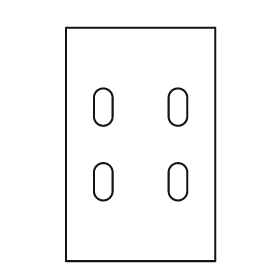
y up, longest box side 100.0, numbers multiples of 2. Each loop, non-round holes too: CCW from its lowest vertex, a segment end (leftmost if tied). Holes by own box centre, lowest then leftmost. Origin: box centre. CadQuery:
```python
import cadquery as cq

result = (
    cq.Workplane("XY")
    .moveTo(-32.0, -50.0)
    .lineTo(32.0, -50.0)
    .lineTo(32.0, 50.0)
    .lineTo(-32.0, 50.0)
    .close()
    .moveTo(-20.0, -20.0)
    .threePointArc((-16.0, -24.0), (-12.0, -20.0))
    .lineTo(-12.0, -12.0)
    .threePointArc((-16.0, -8.0), (-20.0, -12.0))
    .close()
    .moveTo(12.0, -20.0)
    .threePointArc((16.0, -24.0), (20.0, -20.0))
    .lineTo(20.0, -12.0)
    .threePointArc((16.0, -8.0), (12.0, -12.0))
    .close()
    .moveTo(-20.0, 12.0)
    .threePointArc((-16.0, 8.0), (-12.0, 12.0))
    .lineTo(-12.0, 20.0)
    .threePointArc((-16.0, 24.0), (-20.0, 20.0))
    .close()
    .moveTo(12.0, 12.0)
    .threePointArc((16.0, 8.0), (20.0, 12.0))
    .lineTo(20.0, 20.0)
    .threePointArc((16.0, 24.0), (12.0, 20.0))
    .close()
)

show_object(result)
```